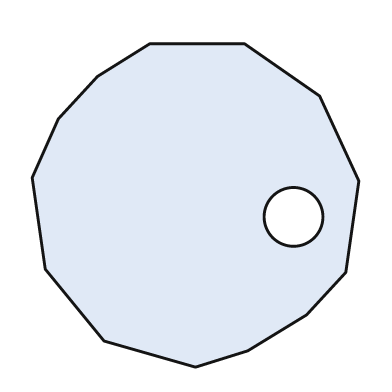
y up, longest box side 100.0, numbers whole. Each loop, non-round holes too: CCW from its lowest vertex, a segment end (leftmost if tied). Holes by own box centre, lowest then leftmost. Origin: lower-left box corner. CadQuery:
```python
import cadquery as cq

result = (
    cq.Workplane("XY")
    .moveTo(50.0, 0.0)
    .lineTo(66.0, 5.0)
    .lineTo(84.0, 16.0)
    .lineTo(96.0, 29.0)
    .lineTo(100.0, 57.0)
    .lineTo(88.0, 83.0)
    .lineTo(65.0, 99.0)
    .lineTo(36.0, 99.0)
    .lineTo(20.0, 89.0)
    .lineTo(8.0, 76.0)
    .lineTo(0.0, 58.0)
    .lineTo(4.0, 30.0)
    .lineTo(22.0, 8.0)
    .close()
    .moveTo(80.0, 46.0)
    .circle(9.0)
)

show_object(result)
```